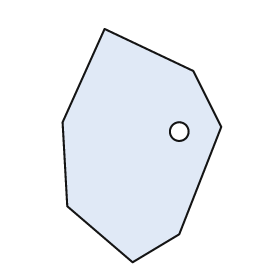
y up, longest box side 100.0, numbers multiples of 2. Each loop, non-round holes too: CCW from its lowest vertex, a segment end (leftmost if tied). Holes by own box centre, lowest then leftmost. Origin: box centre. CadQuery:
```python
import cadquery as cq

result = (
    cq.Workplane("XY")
    .moveTo(-4.0, -50.0)
    .lineTo(16.0, -38.0)
    .lineTo(34.0, 8.0)
    .lineTo(22.0, 32.0)
    .lineTo(-16.0, 50.0)
    .lineTo(-34.0, 10.0)
    .lineTo(-32.0, -26.0)
    .close()
    .moveTo(16.0, 6.0)
    .circle(4.0)
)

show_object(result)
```